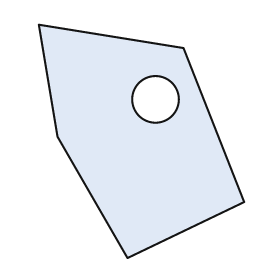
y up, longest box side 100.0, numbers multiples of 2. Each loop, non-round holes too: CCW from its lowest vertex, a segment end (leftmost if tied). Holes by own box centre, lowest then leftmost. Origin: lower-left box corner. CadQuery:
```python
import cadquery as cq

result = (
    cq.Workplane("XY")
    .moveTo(38.0, 0.0)
    .lineTo(88.0, 24.0)
    .lineTo(62.0, 90.0)
    .lineTo(0.0, 100.0)
    .lineTo(8.0, 52.0)
    .close()
    .moveTo(50.0, 68.0)
    .circle(10.0)
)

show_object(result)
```